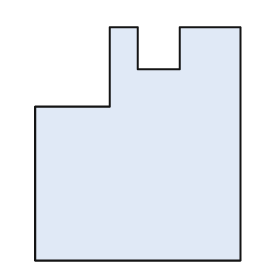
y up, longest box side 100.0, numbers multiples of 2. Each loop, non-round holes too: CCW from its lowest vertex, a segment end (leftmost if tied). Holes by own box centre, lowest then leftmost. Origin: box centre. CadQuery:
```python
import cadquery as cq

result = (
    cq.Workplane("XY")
    .moveTo(-44.0, -50.0)
    .lineTo(44.0, -50.0)
    .lineTo(44.0, 50.0)
    .lineTo(18.0, 50.0)
    .lineTo(18.0, 32.0)
    .lineTo(0.0, 32.0)
    .lineTo(0.0, 50.0)
    .lineTo(-12.0, 50.0)
    .lineTo(-12.0, 16.0)
    .lineTo(-44.0, 16.0)
    .close()
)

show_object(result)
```